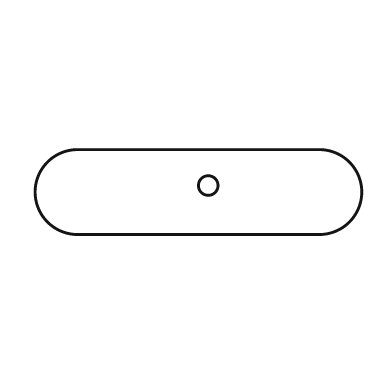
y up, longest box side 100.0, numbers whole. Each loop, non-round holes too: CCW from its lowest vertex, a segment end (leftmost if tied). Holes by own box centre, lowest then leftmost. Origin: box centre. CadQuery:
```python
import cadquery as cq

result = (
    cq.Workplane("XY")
    .moveTo(-37.0, -13.0)
    .lineTo(37.0, -13.0)
    .threePointArc((50.0, 0.0), (37.0, 13.0))
    .lineTo(-37.0, 13.0)
    .threePointArc((-50.0, 0.0), (-37.0, -13.0))
    .close()
    .moveTo(3.0, 2.0)
    .circle(3.0)
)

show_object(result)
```